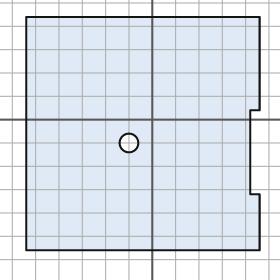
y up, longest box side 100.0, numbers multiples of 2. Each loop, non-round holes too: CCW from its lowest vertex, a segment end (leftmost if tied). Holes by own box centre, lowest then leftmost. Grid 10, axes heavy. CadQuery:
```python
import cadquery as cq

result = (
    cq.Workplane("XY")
    .moveTo(-54.0, -56.0)
    .lineTo(46.0, -56.0)
    .lineTo(46.0, -32.0)
    .lineTo(42.0, -32.0)
    .lineTo(42.0, 4.0)
    .lineTo(46.0, 4.0)
    .lineTo(46.0, 44.0)
    .lineTo(-54.0, 44.0)
    .close()
    .moveTo(-10.0, -10.0)
    .circle(4.0)
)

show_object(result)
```